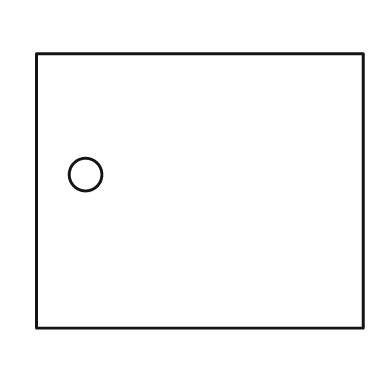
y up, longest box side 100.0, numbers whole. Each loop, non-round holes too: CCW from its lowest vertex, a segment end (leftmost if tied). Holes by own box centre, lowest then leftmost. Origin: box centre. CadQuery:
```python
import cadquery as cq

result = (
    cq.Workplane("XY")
    .moveTo(-50.0, -42.0)
    .lineTo(50.0, -42.0)
    .lineTo(50.0, 42.0)
    .lineTo(-50.0, 42.0)
    .close()
    .moveTo(-35.0, 5.0)
    .circle(5.0)
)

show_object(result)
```